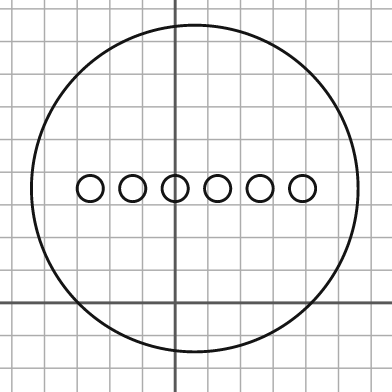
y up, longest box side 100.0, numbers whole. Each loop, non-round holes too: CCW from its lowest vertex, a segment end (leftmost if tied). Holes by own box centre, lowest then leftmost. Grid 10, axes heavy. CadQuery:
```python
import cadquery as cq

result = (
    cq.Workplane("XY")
    .moveTo(6.0, 35.0)
    .circle(50.0)
    .moveTo(-26.0, 35.0)
    .circle(4.0)
    .moveTo(-13.0, 35.0)
    .circle(4.0)
    .moveTo(0.0, 35.0)
    .circle(4.0)
    .moveTo(13.0, 35.0)
    .circle(4.0)
    .moveTo(26.0, 35.0)
    .circle(4.0)
    .moveTo(39.0, 35.0)
    .circle(4.0)
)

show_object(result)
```